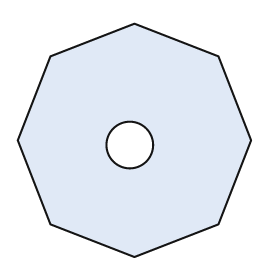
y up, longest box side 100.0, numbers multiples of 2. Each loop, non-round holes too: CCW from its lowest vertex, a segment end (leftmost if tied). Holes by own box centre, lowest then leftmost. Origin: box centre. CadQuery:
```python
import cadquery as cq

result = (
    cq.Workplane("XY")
    .moveTo(0.0, -50.0)
    .lineTo(36.0, -36.0)
    .lineTo(50.0, 0.0)
    .lineTo(36.0, 36.0)
    .lineTo(0.0, 50.0)
    .lineTo(-36.0, 36.0)
    .lineTo(-50.0, 0.0)
    .lineTo(-36.0, -36.0)
    .close()
    .moveTo(-2.0, -2.0)
    .circle(10.0)
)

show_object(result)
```